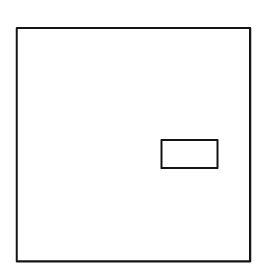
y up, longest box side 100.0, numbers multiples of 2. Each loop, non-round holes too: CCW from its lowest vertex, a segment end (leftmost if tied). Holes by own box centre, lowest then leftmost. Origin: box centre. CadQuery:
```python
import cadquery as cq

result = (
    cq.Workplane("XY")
    .moveTo(-50.0, -50.0)
    .lineTo(50.0, -50.0)
    .lineTo(50.0, 50.0)
    .lineTo(-50.0, 50.0)
    .close()
    .moveTo(12.0, -10.0)
    .lineTo(36.0, -10.0)
    .lineTo(36.0, 2.0)
    .lineTo(12.0, 2.0)
    .close()
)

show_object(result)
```